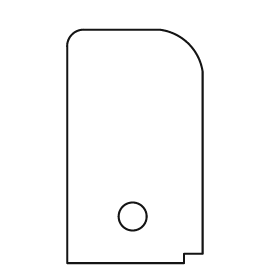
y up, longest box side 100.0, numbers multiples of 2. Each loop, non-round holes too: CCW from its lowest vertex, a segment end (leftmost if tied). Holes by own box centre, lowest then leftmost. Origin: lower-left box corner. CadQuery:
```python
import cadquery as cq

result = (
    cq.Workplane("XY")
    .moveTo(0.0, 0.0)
    .lineTo(50.0, 0.0)
    .lineTo(50.0, 4.0)
    .lineTo(58.0, 4.0)
    .lineTo(58.0, 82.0)
    .threePointArc((52.0, 94.0), (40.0, 100.0))
    .lineTo(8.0, 100.0)
    .threePointArc((2.0, 98.0), (0.0, 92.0))
    .close()
    .moveTo(28.0, 20.0)
    .circle(6.0)
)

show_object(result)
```